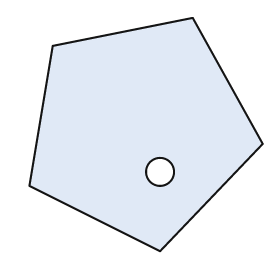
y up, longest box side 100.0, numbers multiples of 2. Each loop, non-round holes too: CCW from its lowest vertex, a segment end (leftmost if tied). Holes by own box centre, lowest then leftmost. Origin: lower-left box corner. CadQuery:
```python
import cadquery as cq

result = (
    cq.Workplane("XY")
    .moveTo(56.0, 0.0)
    .lineTo(100.0, 46.0)
    .lineTo(70.0, 100.0)
    .lineTo(10.0, 88.0)
    .lineTo(0.0, 28.0)
    .close()
    .moveTo(56.0, 34.0)
    .circle(6.0)
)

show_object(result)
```